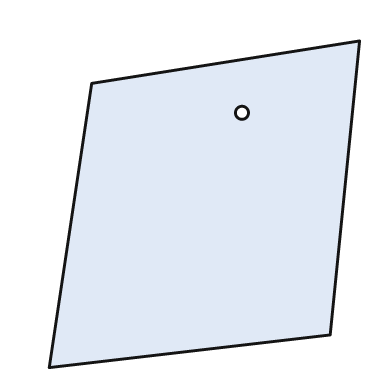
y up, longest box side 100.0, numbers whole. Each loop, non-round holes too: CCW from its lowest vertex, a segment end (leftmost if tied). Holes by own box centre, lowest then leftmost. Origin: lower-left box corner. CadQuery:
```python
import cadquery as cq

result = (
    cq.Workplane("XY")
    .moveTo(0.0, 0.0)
    .lineTo(86.0, 10.0)
    .lineTo(95.0, 100.0)
    .lineTo(13.0, 87.0)
    .close()
    .moveTo(59.0, 78.0)
    .circle(2.0)
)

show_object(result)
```